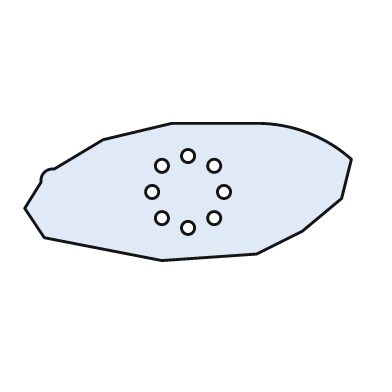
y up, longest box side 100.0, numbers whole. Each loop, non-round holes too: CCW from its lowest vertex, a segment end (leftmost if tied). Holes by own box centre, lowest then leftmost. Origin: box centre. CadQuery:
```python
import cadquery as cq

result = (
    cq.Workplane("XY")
    .moveTo(-8.0, -21.0)
    .lineTo(21.0, -19.0)
    .lineTo(35.0, -12.0)
    .lineTo(47.0, -2.0)
    .lineTo(50.0, 10.0)
    .threePointArc((37.0, 18.0), (22.0, 21.0))
    .lineTo(-5.0, 21.0)
    .lineTo(-26.0, 16.0)
    .lineTo(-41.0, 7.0)
    .threePointArc((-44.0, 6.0), (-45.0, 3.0))
    .lineTo(-50.0, -5.0)
    .lineTo(-44.0, -14.0)
    .close()
    .moveTo(0.0, -11.0)
    .circle(2.0)
    .moveTo(-8.0, -8.0)
    .circle(2.0)
    .moveTo(8.0, -8.0)
    .circle(2.0)
    .moveTo(-11.0, 0.0)
    .circle(2.0)
    .moveTo(11.0, 0.0)
    .circle(2.0)
    .moveTo(-8.0, 8.0)
    .circle(2.0)
    .moveTo(8.0, 8.0)
    .circle(2.0)
    .moveTo(0.0, 11.0)
    .circle(2.0)
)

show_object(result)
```